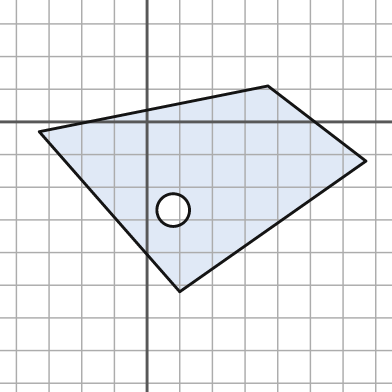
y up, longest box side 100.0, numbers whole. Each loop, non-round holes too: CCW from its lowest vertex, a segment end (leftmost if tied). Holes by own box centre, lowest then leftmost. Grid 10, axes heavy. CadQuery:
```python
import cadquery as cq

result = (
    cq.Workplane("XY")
    .moveTo(10.0, -52.0)
    .lineTo(67.0, -12.0)
    .lineTo(37.0, 11.0)
    .lineTo(-33.0, -3.0)
    .close()
    .moveTo(8.0, -27.0)
    .circle(5.0)
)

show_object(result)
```